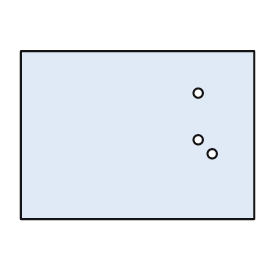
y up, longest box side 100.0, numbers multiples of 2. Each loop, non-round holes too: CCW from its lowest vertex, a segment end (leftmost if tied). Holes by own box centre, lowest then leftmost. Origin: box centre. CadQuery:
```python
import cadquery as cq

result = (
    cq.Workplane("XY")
    .moveTo(-50.0, -36.0)
    .lineTo(50.0, -36.0)
    .lineTo(50.0, 36.0)
    .lineTo(-50.0, 36.0)
    .close()
    .moveTo(32.0, -8.0)
    .circle(2.0)
    .moveTo(26.0, -2.0)
    .circle(2.0)
    .moveTo(26.0, 18.0)
    .circle(2.0)
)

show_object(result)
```